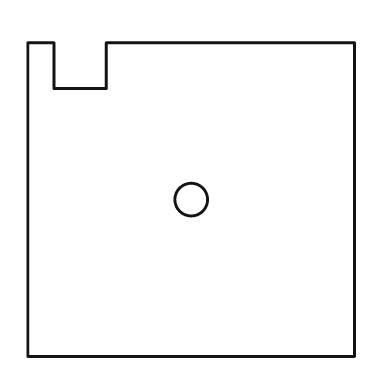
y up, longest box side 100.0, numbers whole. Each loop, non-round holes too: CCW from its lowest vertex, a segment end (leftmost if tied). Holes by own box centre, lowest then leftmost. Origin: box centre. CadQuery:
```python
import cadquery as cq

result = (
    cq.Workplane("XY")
    .moveTo(-50.0, -48.0)
    .lineTo(50.0, -48.0)
    .lineTo(50.0, 48.0)
    .lineTo(-26.0, 48.0)
    .lineTo(-26.0, 34.0)
    .lineTo(-42.0, 34.0)
    .lineTo(-42.0, 48.0)
    .lineTo(-50.0, 48.0)
    .close()
    .moveTo(0.0, 0.0)
    .circle(5.0)
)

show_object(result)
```